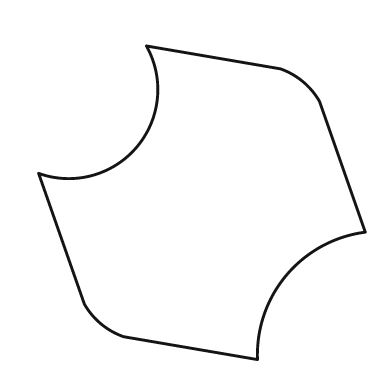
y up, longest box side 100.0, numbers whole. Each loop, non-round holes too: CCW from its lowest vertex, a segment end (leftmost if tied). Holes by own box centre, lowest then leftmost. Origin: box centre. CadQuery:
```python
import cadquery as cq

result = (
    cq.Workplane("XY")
    .moveTo(17.0, -48.0)
    .threePointArc((26.0, -22.0), (50.0, -9.0))
    .lineTo(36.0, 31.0)
    .threePointArc((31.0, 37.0), (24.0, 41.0))
    .lineTo(-17.0, 48.0)
    .threePointArc((-20.0, 17.0), (-50.0, 9.0))
    .lineTo(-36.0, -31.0)
    .threePointArc((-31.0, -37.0), (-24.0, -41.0))
    .close()
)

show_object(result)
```